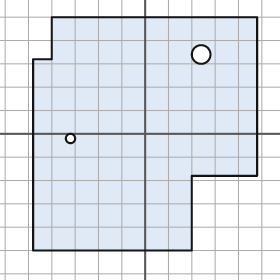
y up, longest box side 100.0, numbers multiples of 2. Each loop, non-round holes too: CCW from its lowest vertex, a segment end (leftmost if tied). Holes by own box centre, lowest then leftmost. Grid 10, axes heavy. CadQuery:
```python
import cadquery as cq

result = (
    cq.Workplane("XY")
    .moveTo(-48.0, -50.0)
    .lineTo(20.0, -50.0)
    .lineTo(20.0, -18.0)
    .lineTo(48.0, -18.0)
    .lineTo(48.0, 50.0)
    .lineTo(-40.0, 50.0)
    .lineTo(-40.0, 32.0)
    .lineTo(-48.0, 32.0)
    .close()
    .moveTo(-32.0, -2.0)
    .circle(2.0)
    .moveTo(24.0, 34.0)
    .circle(4.0)
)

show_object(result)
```